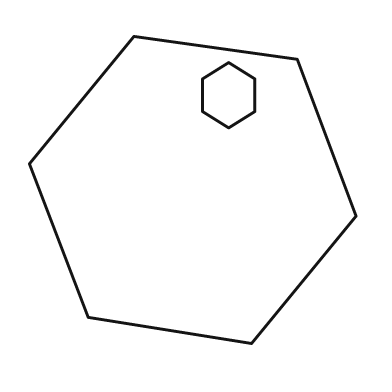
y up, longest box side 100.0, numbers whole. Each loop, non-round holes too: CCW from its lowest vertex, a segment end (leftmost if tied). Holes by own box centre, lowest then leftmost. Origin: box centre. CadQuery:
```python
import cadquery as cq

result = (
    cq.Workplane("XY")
    .moveTo(18.0, -47.0)
    .lineTo(50.0, -8.0)
    .lineTo(32.0, 40.0)
    .lineTo(-18.0, 47.0)
    .lineTo(-50.0, 8.0)
    .lineTo(-32.0, -39.0)
    .close()
    .moveTo(11.0, 19.0)
    .lineTo(19.0, 24.0)
    .lineTo(19.0, 34.0)
    .lineTo(11.0, 39.0)
    .lineTo(3.0, 34.0)
    .lineTo(3.0, 24.0)
    .close()
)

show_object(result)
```